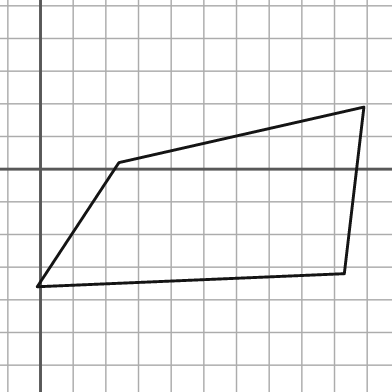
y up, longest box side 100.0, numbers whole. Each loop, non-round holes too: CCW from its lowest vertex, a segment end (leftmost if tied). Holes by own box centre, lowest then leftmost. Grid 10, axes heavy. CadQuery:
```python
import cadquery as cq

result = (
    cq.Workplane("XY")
    .moveTo(-1.0, -36.0)
    .lineTo(93.0, -32.0)
    .lineTo(99.0, 19.0)
    .lineTo(24.0, 2.0)
    .close()
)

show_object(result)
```